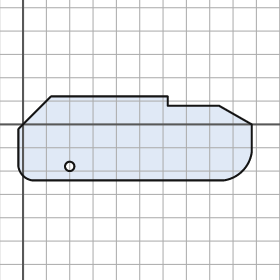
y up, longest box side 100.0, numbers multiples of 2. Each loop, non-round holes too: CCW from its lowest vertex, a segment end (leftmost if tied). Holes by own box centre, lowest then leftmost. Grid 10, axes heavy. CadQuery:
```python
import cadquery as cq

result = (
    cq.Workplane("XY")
    .moveTo(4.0, -24.0)
    .lineTo(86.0, -24.0)
    .threePointArc((94.0, -20.0), (98.0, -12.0))
    .lineTo(98.0, 0.0)
    .lineTo(84.0, 8.0)
    .lineTo(62.0, 8.0)
    .lineTo(62.0, 12.0)
    .lineTo(12.0, 12.0)
    .lineTo(-2.0, -2.0)
    .lineTo(-2.0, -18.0)
    .threePointArc((0.0, -22.0), (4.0, -24.0))
    .close()
    .moveTo(20.0, -18.0)
    .circle(2.0)
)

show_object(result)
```